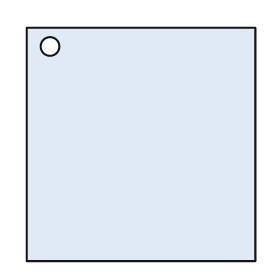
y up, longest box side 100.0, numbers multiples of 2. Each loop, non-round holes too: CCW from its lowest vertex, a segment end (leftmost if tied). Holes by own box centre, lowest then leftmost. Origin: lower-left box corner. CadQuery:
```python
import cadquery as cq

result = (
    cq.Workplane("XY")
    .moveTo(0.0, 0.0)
    .lineTo(98.0, 0.0)
    .lineTo(98.0, 100.0)
    .lineTo(0.0, 100.0)
    .close()
    .moveTo(10.0, 92.0)
    .circle(4.0)
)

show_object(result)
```